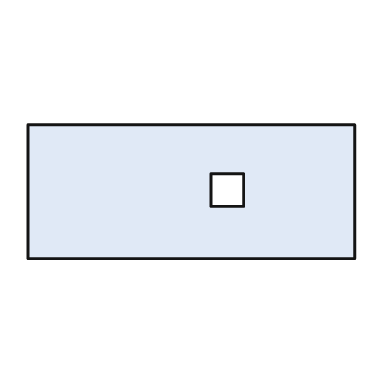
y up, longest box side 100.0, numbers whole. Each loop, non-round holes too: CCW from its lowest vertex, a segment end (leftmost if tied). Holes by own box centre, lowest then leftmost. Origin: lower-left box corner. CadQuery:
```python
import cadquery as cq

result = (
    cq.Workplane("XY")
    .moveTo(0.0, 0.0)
    .lineTo(100.0, 0.0)
    .lineTo(100.0, 41.0)
    .lineTo(0.0, 41.0)
    .close()
    .moveTo(56.0, 16.0)
    .lineTo(66.0, 16.0)
    .lineTo(66.0, 26.0)
    .lineTo(56.0, 26.0)
    .close()
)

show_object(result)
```